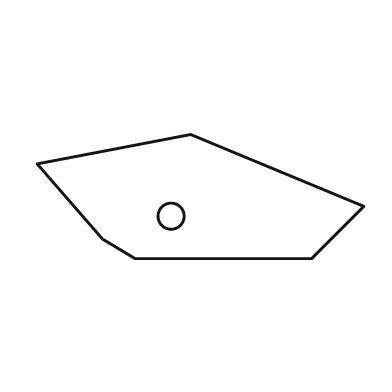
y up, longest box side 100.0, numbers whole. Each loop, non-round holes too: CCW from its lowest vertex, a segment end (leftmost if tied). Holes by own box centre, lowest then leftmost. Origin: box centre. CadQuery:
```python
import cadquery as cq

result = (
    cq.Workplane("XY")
    .moveTo(-20.0, -19.0)
    .lineTo(34.0, -19.0)
    .lineTo(50.0, -3.0)
    .lineTo(-3.0, 19.0)
    .lineTo(-50.0, 10.0)
    .lineTo(-30.0, -13.0)
    .close()
    .moveTo(-9.0, -6.0)
    .circle(4.0)
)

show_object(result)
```